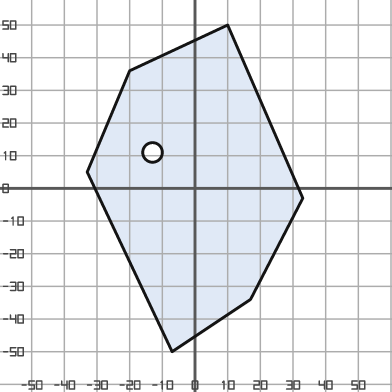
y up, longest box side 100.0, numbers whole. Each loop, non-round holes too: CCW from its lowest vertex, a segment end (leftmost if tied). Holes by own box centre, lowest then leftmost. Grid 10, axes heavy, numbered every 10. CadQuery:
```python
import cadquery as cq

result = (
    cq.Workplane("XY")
    .moveTo(-7.0, -50.0)
    .lineTo(17.0, -34.0)
    .lineTo(33.0, -3.0)
    .lineTo(10.0, 50.0)
    .lineTo(-20.0, 36.0)
    .lineTo(-33.0, 5.0)
    .close()
    .moveTo(-13.0, 11.0)
    .circle(3.0)
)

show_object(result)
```